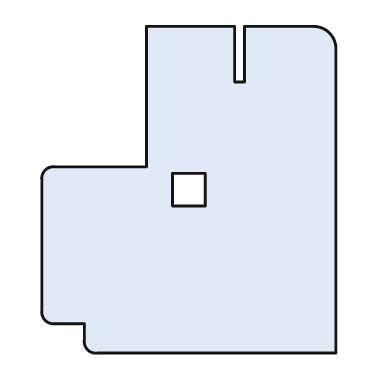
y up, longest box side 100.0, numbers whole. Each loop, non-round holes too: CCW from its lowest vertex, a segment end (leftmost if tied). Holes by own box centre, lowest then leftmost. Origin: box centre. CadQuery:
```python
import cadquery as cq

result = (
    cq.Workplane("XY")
    .moveTo(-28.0, -50.0)
    .lineTo(45.0, -50.0)
    .lineTo(45.0, 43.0)
    .threePointArc((43.0, 48.0), (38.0, 50.0))
    .lineTo(17.0, 50.0)
    .lineTo(17.0, 33.0)
    .lineTo(14.0, 33.0)
    .lineTo(14.0, 50.0)
    .lineTo(-13.0, 50.0)
    .lineTo(-13.0, 7.0)
    .lineTo(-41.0, 7.0)
    .threePointArc((-44.0, 6.0), (-45.0, 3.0))
    .lineTo(-45.0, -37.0)
    .threePointArc((-44.0, -40.0), (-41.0, -41.0))
    .lineTo(-32.0, -41.0)
    .lineTo(-32.0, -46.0)
    .threePointArc((-31.0, -49.0), (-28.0, -50.0))
    .close()
    .moveTo(-5.0, -5.0)
    .lineTo(5.0, -5.0)
    .lineTo(5.0, 5.0)
    .lineTo(-5.0, 5.0)
    .close()
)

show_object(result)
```